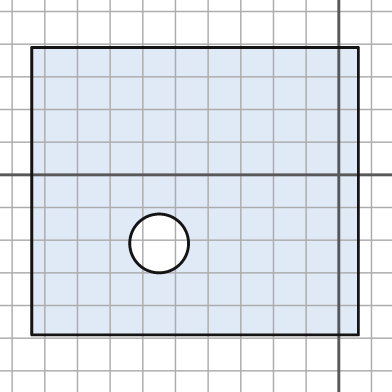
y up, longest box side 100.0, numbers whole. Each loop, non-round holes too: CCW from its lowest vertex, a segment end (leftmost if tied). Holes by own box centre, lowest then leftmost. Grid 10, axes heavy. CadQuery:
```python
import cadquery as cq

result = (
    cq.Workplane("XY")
    .moveTo(-94.0, -49.0)
    .lineTo(6.0, -49.0)
    .lineTo(6.0, 39.0)
    .lineTo(-94.0, 39.0)
    .close()
    .moveTo(-55.0, -21.0)
    .circle(9.0)
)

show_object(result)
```